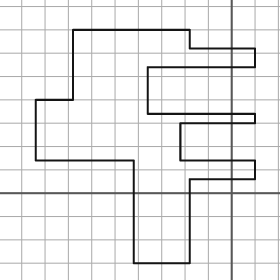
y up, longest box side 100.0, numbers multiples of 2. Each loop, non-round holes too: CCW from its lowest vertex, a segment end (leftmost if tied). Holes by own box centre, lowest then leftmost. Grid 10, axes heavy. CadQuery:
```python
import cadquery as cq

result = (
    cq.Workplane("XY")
    .moveTo(-42.0, -30.0)
    .lineTo(-18.0, -30.0)
    .lineTo(-18.0, 6.0)
    .lineTo(10.0, 6.0)
    .lineTo(10.0, 14.0)
    .lineTo(-22.0, 14.0)
    .lineTo(-22.0, 30.0)
    .lineTo(10.0, 30.0)
    .lineTo(10.0, 34.0)
    .lineTo(-36.0, 34.0)
    .lineTo(-36.0, 54.0)
    .lineTo(10.0, 54.0)
    .lineTo(10.0, 62.0)
    .lineTo(-18.0, 62.0)
    .lineTo(-18.0, 70.0)
    .lineTo(-68.0, 70.0)
    .lineTo(-68.0, 40.0)
    .lineTo(-84.0, 40.0)
    .lineTo(-84.0, 14.0)
    .lineTo(-42.0, 14.0)
    .close()
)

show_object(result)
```